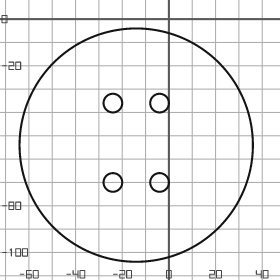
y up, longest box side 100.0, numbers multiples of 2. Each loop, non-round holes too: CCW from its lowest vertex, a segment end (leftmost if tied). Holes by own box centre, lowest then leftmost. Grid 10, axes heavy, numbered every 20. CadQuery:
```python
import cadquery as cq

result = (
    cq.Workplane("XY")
    .moveTo(-14.0, -54.0)
    .circle(50.0)
    .moveTo(-24.0, -70.0)
    .circle(4.0)
    .moveTo(-4.0, -70.0)
    .circle(4.0)
    .moveTo(-24.0, -36.0)
    .circle(4.0)
    .moveTo(-4.0, -36.0)
    .circle(4.0)
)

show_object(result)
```